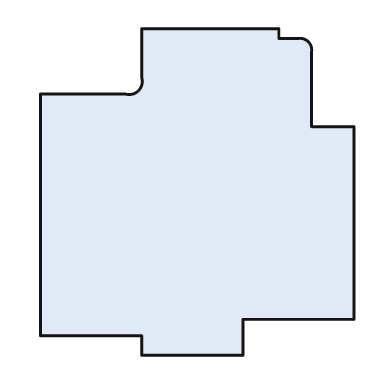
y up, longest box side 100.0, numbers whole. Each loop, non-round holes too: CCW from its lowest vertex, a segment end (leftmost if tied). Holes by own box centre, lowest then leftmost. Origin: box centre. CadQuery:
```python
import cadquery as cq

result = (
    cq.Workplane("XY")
    .moveTo(-17.0, -50.0)
    .lineTo(14.0, -50.0)
    .lineTo(14.0, -39.0)
    .lineTo(48.0, -39.0)
    .lineTo(48.0, 20.0)
    .lineTo(35.0, 20.0)
    .lineTo(35.0, 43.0)
    .threePointArc((34.0, 46.0), (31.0, 47.0))
    .lineTo(25.0, 47.0)
    .lineTo(25.0, 50.0)
    .lineTo(-17.0, 50.0)
    .lineTo(-17.0, 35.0)
    .threePointArc((-18.0, 31.0), (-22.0, 30.0))
    .lineTo(-48.0, 30.0)
    .lineTo(-48.0, -44.0)
    .lineTo(-17.0, -44.0)
    .close()
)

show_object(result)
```